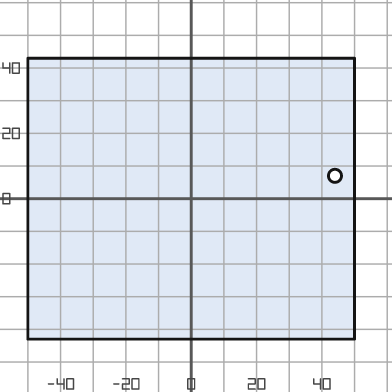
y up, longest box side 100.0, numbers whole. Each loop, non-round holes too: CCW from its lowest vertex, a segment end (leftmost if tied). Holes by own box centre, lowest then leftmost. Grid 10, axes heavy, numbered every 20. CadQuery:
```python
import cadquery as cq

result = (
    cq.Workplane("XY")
    .moveTo(-50.0, -43.0)
    .lineTo(50.0, -43.0)
    .lineTo(50.0, 43.0)
    .lineTo(-50.0, 43.0)
    .close()
    .moveTo(44.0, 7.0)
    .circle(2.0)
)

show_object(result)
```